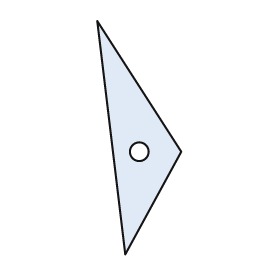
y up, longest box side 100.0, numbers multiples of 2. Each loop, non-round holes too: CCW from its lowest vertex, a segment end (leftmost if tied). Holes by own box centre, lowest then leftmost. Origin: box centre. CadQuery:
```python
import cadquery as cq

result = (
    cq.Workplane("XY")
    .moveTo(-6.0, -50.0)
    .lineTo(18.0, -6.0)
    .lineTo(-18.0, 50.0)
    .close()
    .moveTo(0.0, -6.0)
    .circle(4.0)
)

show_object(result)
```